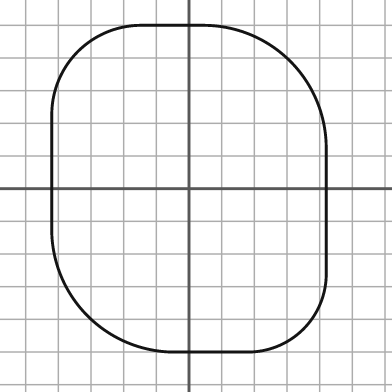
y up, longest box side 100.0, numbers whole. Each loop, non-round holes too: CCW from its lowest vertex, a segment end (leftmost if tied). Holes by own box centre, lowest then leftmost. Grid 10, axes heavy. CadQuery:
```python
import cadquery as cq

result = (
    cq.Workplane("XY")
    .moveTo(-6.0, -50.0)
    .lineTo(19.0, -50.0)
    .threePointArc((35.0, -43.0), (42.0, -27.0))
    .lineTo(42.0, 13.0)
    .threePointArc((31.0, 39.0), (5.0, 50.0))
    .lineTo(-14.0, 50.0)
    .threePointArc((-34.0, 42.0), (-42.0, 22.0))
    .lineTo(-42.0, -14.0)
    .threePointArc((-31.0, -39.0), (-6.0, -50.0))
    .close()
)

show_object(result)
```